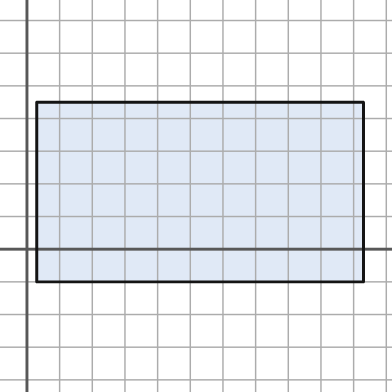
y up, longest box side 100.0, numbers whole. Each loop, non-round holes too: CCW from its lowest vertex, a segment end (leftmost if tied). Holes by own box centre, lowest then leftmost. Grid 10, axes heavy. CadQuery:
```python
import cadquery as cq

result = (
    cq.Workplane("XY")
    .moveTo(3.0, -10.0)
    .lineTo(103.0, -10.0)
    .lineTo(103.0, 45.0)
    .lineTo(3.0, 45.0)
    .close()
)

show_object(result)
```